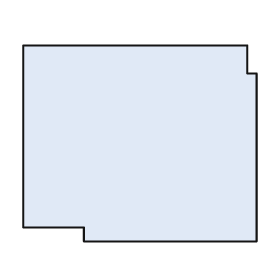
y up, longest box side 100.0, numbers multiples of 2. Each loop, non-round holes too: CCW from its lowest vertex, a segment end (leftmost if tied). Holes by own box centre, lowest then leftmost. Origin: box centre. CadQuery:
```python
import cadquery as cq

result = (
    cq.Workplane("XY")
    .moveTo(-24.0, -42.0)
    .lineTo(50.0, -42.0)
    .lineTo(50.0, 30.0)
    .lineTo(46.0, 30.0)
    .lineTo(46.0, 42.0)
    .lineTo(-50.0, 42.0)
    .lineTo(-50.0, -36.0)
    .lineTo(-24.0, -36.0)
    .close()
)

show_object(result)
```